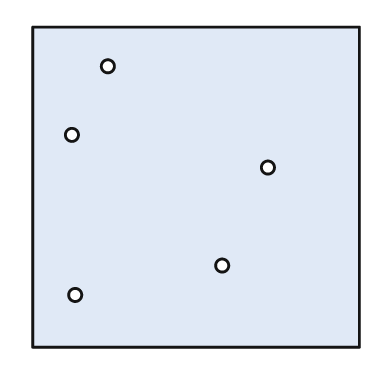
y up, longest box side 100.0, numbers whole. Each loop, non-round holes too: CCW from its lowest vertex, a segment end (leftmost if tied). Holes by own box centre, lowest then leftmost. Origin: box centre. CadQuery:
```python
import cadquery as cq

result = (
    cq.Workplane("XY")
    .moveTo(-50.0, -49.0)
    .lineTo(50.0, -49.0)
    .lineTo(50.0, 49.0)
    .lineTo(-50.0, 49.0)
    .close()
    .moveTo(-37.0, -33.0)
    .circle(2.0)
    .moveTo(8.0, -24.0)
    .circle(2.0)
    .moveTo(22.0, 6.0)
    .circle(2.0)
    .moveTo(-38.0, 16.0)
    .circle(2.0)
    .moveTo(-27.0, 37.0)
    .circle(2.0)
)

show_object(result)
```